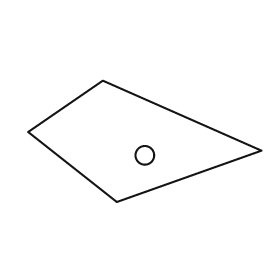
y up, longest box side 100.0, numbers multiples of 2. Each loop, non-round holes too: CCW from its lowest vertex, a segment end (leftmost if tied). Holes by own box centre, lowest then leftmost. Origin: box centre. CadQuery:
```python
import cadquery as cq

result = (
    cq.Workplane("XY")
    .moveTo(-12.0, -26.0)
    .lineTo(50.0, -4.0)
    .lineTo(-18.0, 26.0)
    .lineTo(-50.0, 4.0)
    .close()
    .moveTo(0.0, -6.0)
    .circle(4.0)
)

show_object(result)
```